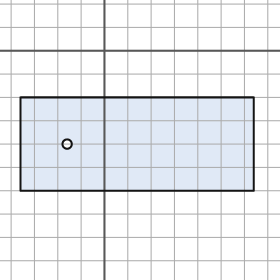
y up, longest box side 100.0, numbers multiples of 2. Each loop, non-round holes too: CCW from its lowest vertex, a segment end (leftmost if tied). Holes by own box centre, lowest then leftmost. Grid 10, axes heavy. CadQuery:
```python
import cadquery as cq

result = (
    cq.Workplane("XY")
    .moveTo(-36.0, -60.0)
    .lineTo(64.0, -60.0)
    .lineTo(64.0, -20.0)
    .lineTo(-36.0, -20.0)
    .close()
    .moveTo(-16.0, -40.0)
    .circle(2.0)
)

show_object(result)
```